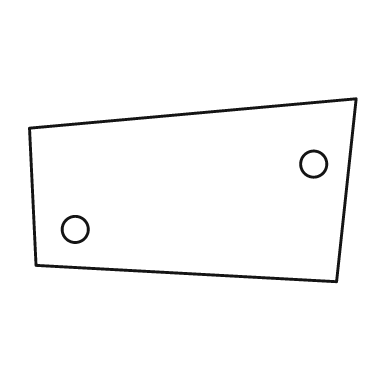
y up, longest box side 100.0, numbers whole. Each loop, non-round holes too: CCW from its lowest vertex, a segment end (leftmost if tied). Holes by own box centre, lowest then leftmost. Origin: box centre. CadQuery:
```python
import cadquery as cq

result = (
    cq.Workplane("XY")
    .moveTo(44.0, -28.0)
    .lineTo(50.0, 28.0)
    .lineTo(-50.0, 19.0)
    .lineTo(-48.0, -23.0)
    .close()
    .moveTo(-36.0, -12.0)
    .circle(4.0)
    .moveTo(37.0, 8.0)
    .circle(4.0)
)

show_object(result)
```